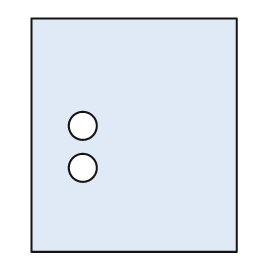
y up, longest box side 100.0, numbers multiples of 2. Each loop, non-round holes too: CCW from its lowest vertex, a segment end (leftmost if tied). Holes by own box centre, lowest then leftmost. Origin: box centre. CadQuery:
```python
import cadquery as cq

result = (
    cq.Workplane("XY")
    .moveTo(-44.0, -50.0)
    .lineTo(44.0, -50.0)
    .lineTo(44.0, 50.0)
    .lineTo(-44.0, 50.0)
    .close()
    .moveTo(-22.0, -14.0)
    .circle(6.0)
    .moveTo(-22.0, 4.0)
    .circle(6.0)
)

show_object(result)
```